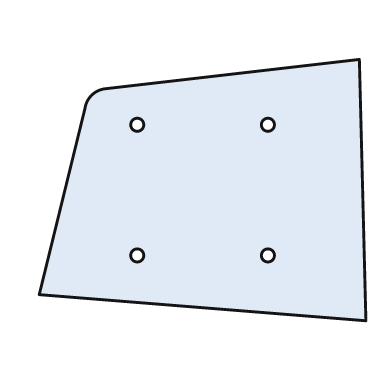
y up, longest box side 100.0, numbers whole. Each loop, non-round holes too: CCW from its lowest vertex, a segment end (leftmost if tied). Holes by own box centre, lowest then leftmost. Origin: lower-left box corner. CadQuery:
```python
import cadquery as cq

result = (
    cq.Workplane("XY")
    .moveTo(100.0, 0.0)
    .lineTo(98.0, 80.0)
    .lineTo(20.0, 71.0)
    .threePointArc((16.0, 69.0), (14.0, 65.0))
    .lineTo(0.0, 8.0)
    .close()
    .moveTo(30.0, 20.0)
    .circle(2.0)
    .moveTo(70.0, 20.0)
    .circle(2.0)
    .moveTo(30.0, 60.0)
    .circle(2.0)
    .moveTo(70.0, 60.0)
    .circle(2.0)
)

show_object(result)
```